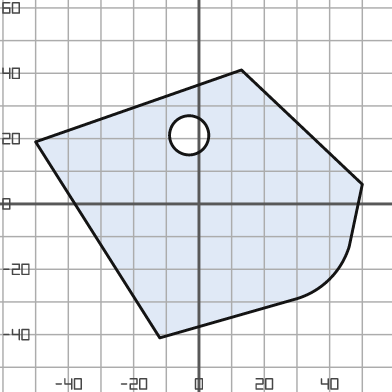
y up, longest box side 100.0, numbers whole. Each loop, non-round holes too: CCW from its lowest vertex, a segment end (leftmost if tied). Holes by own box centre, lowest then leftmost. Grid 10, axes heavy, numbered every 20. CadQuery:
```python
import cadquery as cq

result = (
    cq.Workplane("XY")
    .moveTo(-12.0, -41.0)
    .lineTo(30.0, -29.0)
    .threePointArc((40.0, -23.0), (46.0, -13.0))
    .lineTo(50.0, 6.0)
    .lineTo(13.0, 41.0)
    .lineTo(-50.0, 19.0)
    .close()
    .moveTo(-3.0, 21.0)
    .circle(6.0)
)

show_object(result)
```